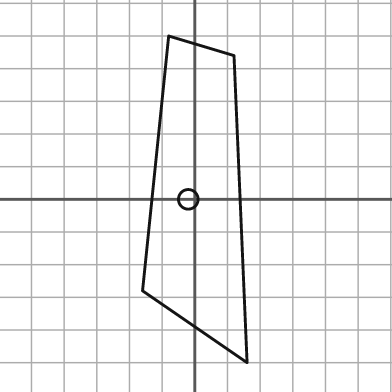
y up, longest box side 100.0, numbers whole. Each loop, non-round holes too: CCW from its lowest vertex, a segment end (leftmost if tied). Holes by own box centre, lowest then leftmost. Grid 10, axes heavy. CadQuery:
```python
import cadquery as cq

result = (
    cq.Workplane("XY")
    .moveTo(16.0, -50.0)
    .lineTo(12.0, 44.0)
    .lineTo(-8.0, 50.0)
    .lineTo(-16.0, -28.0)
    .close()
    .moveTo(-2.0, 0.0)
    .circle(3.0)
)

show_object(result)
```